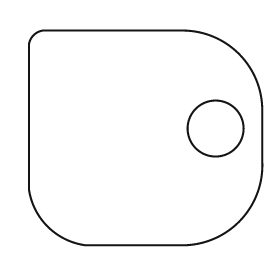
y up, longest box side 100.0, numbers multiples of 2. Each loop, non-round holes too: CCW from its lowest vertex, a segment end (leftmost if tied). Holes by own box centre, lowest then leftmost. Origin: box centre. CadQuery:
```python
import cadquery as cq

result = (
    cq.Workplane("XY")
    .moveTo(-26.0, -46.0)
    .lineTo(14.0, -46.0)
    .threePointArc((40.0, -36.0), (50.0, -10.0))
    .lineTo(50.0, 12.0)
    .threePointArc((40.0, 36.0), (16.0, 46.0))
    .lineTo(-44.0, 46.0)
    .threePointArc((-48.0, 44.0), (-50.0, 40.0))
    .lineTo(-50.0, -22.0)
    .threePointArc((-42.0, -38.0), (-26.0, -46.0))
    .close()
    .moveTo(30.0, 4.0)
    .circle(12.0)
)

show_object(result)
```